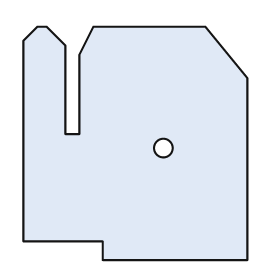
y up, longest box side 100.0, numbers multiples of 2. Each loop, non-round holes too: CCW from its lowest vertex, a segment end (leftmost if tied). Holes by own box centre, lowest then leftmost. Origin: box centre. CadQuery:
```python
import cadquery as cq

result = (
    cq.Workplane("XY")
    .moveTo(-14.0, -50.0)
    .lineTo(48.0, -50.0)
    .lineTo(48.0, 28.0)
    .lineTo(30.0, 50.0)
    .lineTo(-18.0, 50.0)
    .lineTo(-24.0, 38.0)
    .lineTo(-24.0, 4.0)
    .lineTo(-30.0, 4.0)
    .lineTo(-30.0, 42.0)
    .lineTo(-38.0, 50.0)
    .lineTo(-42.0, 50.0)
    .lineTo(-48.0, 44.0)
    .lineTo(-48.0, -42.0)
    .lineTo(-14.0, -42.0)
    .close()
    .moveTo(12.0, -2.0)
    .circle(4.0)
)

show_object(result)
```